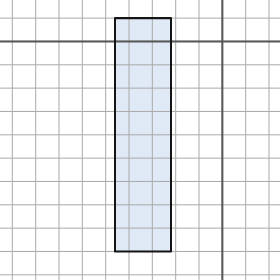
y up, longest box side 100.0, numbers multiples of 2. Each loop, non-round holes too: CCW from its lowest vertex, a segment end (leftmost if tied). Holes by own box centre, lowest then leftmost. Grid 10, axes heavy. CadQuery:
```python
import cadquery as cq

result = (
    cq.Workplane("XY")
    .moveTo(-46.0, -90.0)
    .lineTo(-22.0, -90.0)
    .lineTo(-22.0, 10.0)
    .lineTo(-46.0, 10.0)
    .close()
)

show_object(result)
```